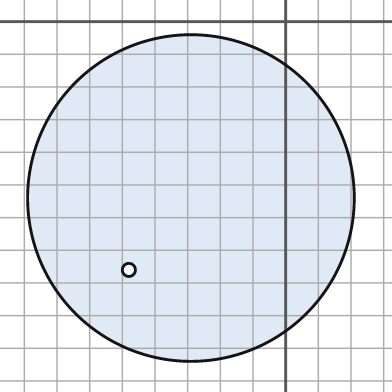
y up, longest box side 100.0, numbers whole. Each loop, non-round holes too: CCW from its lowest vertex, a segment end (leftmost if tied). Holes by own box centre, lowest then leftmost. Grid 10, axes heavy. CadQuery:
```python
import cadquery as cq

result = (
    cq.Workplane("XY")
    .moveTo(-29.0, -54.0)
    .circle(50.0)
    .moveTo(-48.0, -76.0)
    .circle(2.0)
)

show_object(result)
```